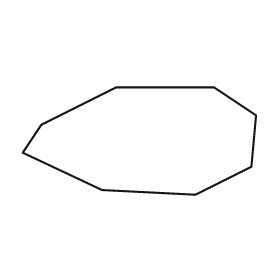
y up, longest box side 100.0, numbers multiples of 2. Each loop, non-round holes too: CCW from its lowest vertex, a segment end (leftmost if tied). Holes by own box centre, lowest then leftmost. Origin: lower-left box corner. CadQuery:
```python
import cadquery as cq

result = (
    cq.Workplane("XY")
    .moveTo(74.0, 0.0)
    .lineTo(98.0, 12.0)
    .lineTo(100.0, 34.0)
    .lineTo(82.0, 46.0)
    .lineTo(40.0, 46.0)
    .lineTo(8.0, 30.0)
    .lineTo(0.0, 18.0)
    .lineTo(34.0, 2.0)
    .close()
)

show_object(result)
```